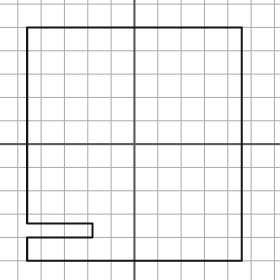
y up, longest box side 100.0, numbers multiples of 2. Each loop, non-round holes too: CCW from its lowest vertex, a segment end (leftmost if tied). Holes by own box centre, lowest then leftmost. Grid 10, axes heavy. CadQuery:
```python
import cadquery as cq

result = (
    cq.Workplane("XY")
    .moveTo(-46.0, -50.0)
    .lineTo(46.0, -50.0)
    .lineTo(46.0, 50.0)
    .lineTo(-46.0, 50.0)
    .lineTo(-46.0, -34.0)
    .lineTo(-18.0, -34.0)
    .lineTo(-18.0, -40.0)
    .lineTo(-46.0, -40.0)
    .close()
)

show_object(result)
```